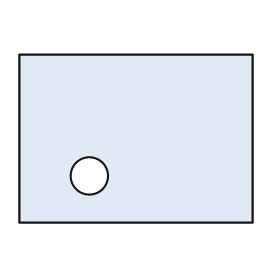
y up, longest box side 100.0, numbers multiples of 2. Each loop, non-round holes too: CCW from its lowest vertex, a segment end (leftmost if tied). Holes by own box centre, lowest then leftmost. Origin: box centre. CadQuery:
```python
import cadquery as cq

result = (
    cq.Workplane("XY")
    .moveTo(-50.0, -36.0)
    .lineTo(50.0, -36.0)
    .lineTo(50.0, 36.0)
    .lineTo(-50.0, 36.0)
    .close()
    .moveTo(-20.0, -16.0)
    .circle(8.0)
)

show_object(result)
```